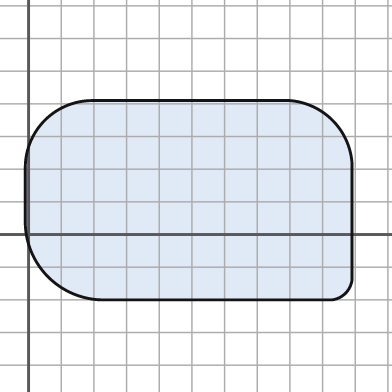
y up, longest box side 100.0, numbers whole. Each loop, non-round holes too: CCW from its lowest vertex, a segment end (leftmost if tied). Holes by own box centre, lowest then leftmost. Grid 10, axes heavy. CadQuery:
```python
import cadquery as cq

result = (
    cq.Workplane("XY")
    .moveTo(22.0, -20.0)
    .lineTo(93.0, -20.0)
    .threePointArc((97.0, -18.0), (99.0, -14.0))
    .lineTo(99.0, 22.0)
    .threePointArc((93.0, 35.0), (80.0, 41.0))
    .lineTo(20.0, 41.0)
    .threePointArc((5.0, 35.0), (-1.0, 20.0))
    .lineTo(-1.0, 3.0)
    .threePointArc((6.0, -13.0), (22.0, -20.0))
    .close()
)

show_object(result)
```